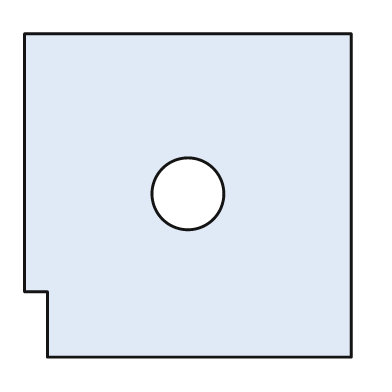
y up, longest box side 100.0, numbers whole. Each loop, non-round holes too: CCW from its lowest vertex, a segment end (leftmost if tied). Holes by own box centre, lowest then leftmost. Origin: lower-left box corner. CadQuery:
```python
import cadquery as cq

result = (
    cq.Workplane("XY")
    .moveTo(7.0, 0.0)
    .lineTo(100.0, 0.0)
    .lineTo(100.0, 99.0)
    .lineTo(0.0, 99.0)
    .lineTo(0.0, 20.0)
    .lineTo(7.0, 20.0)
    .close()
    .moveTo(50.0, 50.0)
    .circle(11.0)
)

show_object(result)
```